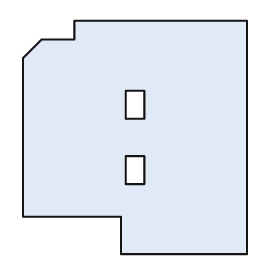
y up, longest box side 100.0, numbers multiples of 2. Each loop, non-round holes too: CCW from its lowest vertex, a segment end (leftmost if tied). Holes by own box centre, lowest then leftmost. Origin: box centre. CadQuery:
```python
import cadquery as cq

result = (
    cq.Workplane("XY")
    .moveTo(-6.0, -50.0)
    .lineTo(48.0, -50.0)
    .lineTo(48.0, 50.0)
    .lineTo(-26.0, 50.0)
    .lineTo(-26.0, 42.0)
    .lineTo(-40.0, 42.0)
    .lineTo(-48.0, 34.0)
    .lineTo(-48.0, -34.0)
    .lineTo(-6.0, -34.0)
    .close()
    .moveTo(-4.0, -20.0)
    .lineTo(4.0, -20.0)
    .lineTo(4.0, -8.0)
    .lineTo(-4.0, -8.0)
    .close()
    .moveTo(-4.0, 8.0)
    .lineTo(4.0, 8.0)
    .lineTo(4.0, 20.0)
    .lineTo(-4.0, 20.0)
    .close()
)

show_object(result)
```